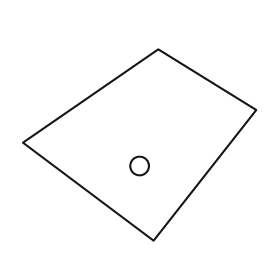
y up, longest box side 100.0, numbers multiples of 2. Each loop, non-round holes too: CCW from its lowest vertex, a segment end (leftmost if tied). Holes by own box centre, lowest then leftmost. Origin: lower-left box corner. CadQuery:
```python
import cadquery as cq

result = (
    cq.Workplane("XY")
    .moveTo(56.0, 0.0)
    .lineTo(100.0, 56.0)
    .lineTo(58.0, 82.0)
    .lineTo(0.0, 42.0)
    .close()
    .moveTo(50.0, 32.0)
    .circle(4.0)
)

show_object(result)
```